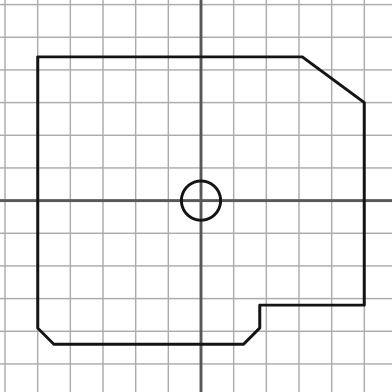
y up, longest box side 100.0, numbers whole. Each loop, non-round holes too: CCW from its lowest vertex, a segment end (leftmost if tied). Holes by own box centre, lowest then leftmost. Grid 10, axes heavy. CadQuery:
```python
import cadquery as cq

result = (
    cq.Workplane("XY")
    .moveTo(-45.0, -44.0)
    .lineTo(13.0, -44.0)
    .lineTo(18.0, -39.0)
    .lineTo(18.0, -32.0)
    .lineTo(50.0, -32.0)
    .lineTo(50.0, 30.0)
    .lineTo(31.0, 44.0)
    .lineTo(-50.0, 44.0)
    .lineTo(-50.0, -39.0)
    .close()
    .moveTo(0.0, 0.0)
    .circle(6.0)
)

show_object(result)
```